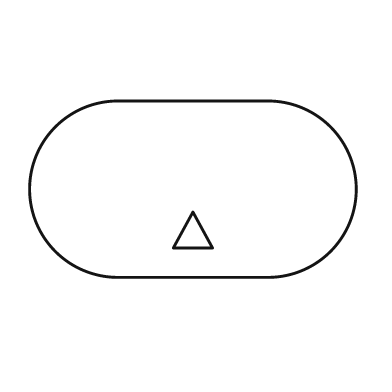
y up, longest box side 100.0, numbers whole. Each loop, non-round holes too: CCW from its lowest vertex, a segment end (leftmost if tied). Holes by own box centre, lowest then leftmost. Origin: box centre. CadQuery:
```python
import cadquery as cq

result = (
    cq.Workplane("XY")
    .moveTo(-23.0, -27.0)
    .lineTo(23.0, -27.0)
    .threePointArc((50.0, 0.0), (23.0, 27.0))
    .lineTo(-23.0, 27.0)
    .threePointArc((-50.0, 0.0), (-23.0, -27.0))
    .close()
    .moveTo(-6.0, -18.0)
    .lineTo(6.0, -18.0)
    .lineTo(0.0, -7.0)
    .close()
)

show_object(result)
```